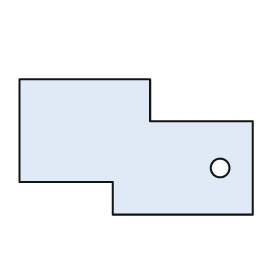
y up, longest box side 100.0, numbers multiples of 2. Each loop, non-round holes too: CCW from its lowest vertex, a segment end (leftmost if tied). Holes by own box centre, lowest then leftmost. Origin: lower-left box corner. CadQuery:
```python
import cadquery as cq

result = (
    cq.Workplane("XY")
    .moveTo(40.0, 0.0)
    .lineTo(100.0, 0.0)
    .lineTo(100.0, 40.0)
    .lineTo(56.0, 40.0)
    .lineTo(56.0, 58.0)
    .lineTo(0.0, 58.0)
    .lineTo(0.0, 14.0)
    .lineTo(40.0, 14.0)
    .close()
    .moveTo(86.0, 20.0)
    .circle(4.0)
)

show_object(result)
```